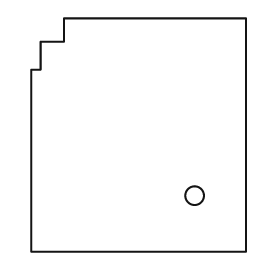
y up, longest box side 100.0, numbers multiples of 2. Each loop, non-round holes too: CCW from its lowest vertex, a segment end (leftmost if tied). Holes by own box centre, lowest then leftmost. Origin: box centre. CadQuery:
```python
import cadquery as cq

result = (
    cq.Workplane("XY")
    .moveTo(-46.0, -50.0)
    .lineTo(46.0, -50.0)
    .lineTo(46.0, 50.0)
    .lineTo(-32.0, 50.0)
    .lineTo(-32.0, 40.0)
    .lineTo(-42.0, 40.0)
    .lineTo(-42.0, 28.0)
    .lineTo(-46.0, 28.0)
    .close()
    .moveTo(24.0, -26.0)
    .circle(4.0)
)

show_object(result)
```